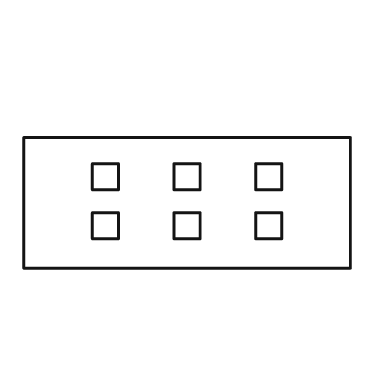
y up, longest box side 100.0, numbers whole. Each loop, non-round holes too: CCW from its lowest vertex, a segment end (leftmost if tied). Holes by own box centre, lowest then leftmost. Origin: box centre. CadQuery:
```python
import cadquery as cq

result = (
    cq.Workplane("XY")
    .moveTo(-50.0, -20.0)
    .lineTo(50.0, -20.0)
    .lineTo(50.0, 20.0)
    .lineTo(-50.0, 20.0)
    .close()
    .moveTo(-29.0, -11.0)
    .lineTo(-21.0, -11.0)
    .lineTo(-21.0, -3.0)
    .lineTo(-29.0, -3.0)
    .close()
    .moveTo(-4.0, -11.0)
    .lineTo(4.0, -11.0)
    .lineTo(4.0, -3.0)
    .lineTo(-4.0, -3.0)
    .close()
    .moveTo(21.0, -11.0)
    .lineTo(29.0, -11.0)
    .lineTo(29.0, -3.0)
    .lineTo(21.0, -3.0)
    .close()
    .moveTo(-29.0, 4.0)
    .lineTo(-21.0, 4.0)
    .lineTo(-21.0, 12.0)
    .lineTo(-29.0, 12.0)
    .close()
    .moveTo(-4.0, 4.0)
    .lineTo(4.0, 4.0)
    .lineTo(4.0, 12.0)
    .lineTo(-4.0, 12.0)
    .close()
    .moveTo(21.0, 4.0)
    .lineTo(29.0, 4.0)
    .lineTo(29.0, 12.0)
    .lineTo(21.0, 12.0)
    .close()
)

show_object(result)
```